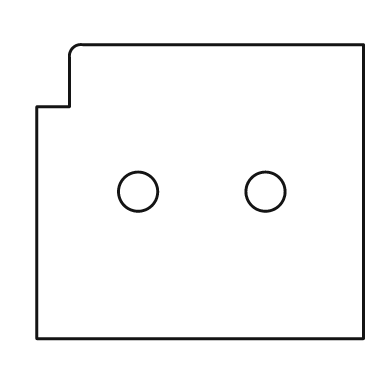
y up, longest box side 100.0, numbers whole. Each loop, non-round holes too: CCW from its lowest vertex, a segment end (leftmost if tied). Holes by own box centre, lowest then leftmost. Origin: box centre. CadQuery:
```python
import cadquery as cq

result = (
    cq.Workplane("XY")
    .moveTo(-50.0, -45.0)
    .lineTo(50.0, -45.0)
    .lineTo(50.0, 45.0)
    .lineTo(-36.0, 45.0)
    .threePointArc((-39.0, 44.0), (-40.0, 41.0))
    .lineTo(-40.0, 26.0)
    .lineTo(-50.0, 26.0)
    .close()
    .moveTo(-19.0, 0.0)
    .circle(6.0)
    .moveTo(20.0, 0.0)
    .circle(6.0)
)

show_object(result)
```